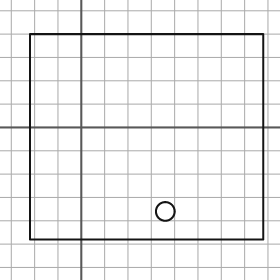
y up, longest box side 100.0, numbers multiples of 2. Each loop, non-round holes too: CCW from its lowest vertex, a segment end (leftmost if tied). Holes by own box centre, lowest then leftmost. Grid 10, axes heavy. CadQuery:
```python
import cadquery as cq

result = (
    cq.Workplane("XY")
    .moveTo(-22.0, -48.0)
    .lineTo(78.0, -48.0)
    .lineTo(78.0, 40.0)
    .lineTo(-22.0, 40.0)
    .close()
    .moveTo(36.0, -36.0)
    .circle(4.0)
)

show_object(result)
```